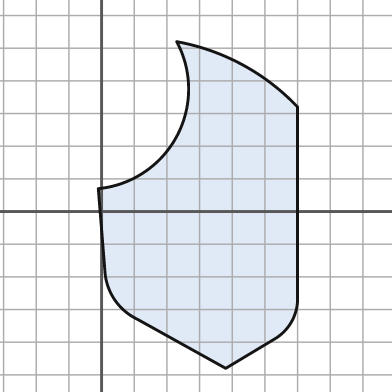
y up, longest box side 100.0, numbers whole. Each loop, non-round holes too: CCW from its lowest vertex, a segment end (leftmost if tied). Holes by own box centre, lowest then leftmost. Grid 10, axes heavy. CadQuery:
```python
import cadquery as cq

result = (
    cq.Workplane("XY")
    .moveTo(38.0, -48.0)
    .lineTo(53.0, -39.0)
    .threePointArc((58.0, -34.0), (60.0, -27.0))
    .lineTo(60.0, 32.0)
    .threePointArc((43.0, 45.0), (23.0, 52.0))
    .threePointArc((23.0, 23.0), (-1.0, 7.0))
    .lineTo(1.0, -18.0)
    .threePointArc((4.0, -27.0), (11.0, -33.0))
    .close()
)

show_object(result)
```